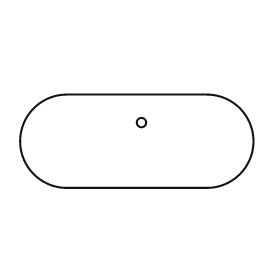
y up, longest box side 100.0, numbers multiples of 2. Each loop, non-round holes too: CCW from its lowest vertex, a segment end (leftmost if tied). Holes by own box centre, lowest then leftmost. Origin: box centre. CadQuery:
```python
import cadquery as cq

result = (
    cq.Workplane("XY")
    .moveTo(-30.0, -20.0)
    .lineTo(30.0, -20.0)
    .threePointArc((50.0, 0.0), (30.0, 20.0))
    .lineTo(-30.0, 20.0)
    .threePointArc((-50.0, 0.0), (-30.0, -20.0))
    .close()
    .moveTo(2.0, 8.0)
    .circle(2.0)
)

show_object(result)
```